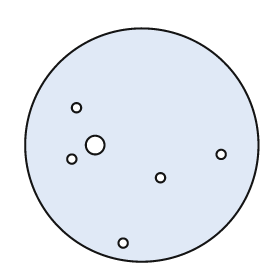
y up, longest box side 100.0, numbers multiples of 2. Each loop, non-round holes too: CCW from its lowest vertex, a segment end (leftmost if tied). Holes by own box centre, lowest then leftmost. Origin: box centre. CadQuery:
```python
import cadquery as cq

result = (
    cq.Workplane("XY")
    .moveTo(0.0, 0.0)
    .circle(50.0)
    .moveTo(-8.0, -42.0)
    .circle(2.0)
    .moveTo(8.0, -14.0)
    .circle(2.0)
    .moveTo(-30.0, -6.0)
    .circle(2.0)
    .moveTo(34.0, -4.0)
    .circle(2.0)
    .moveTo(-20.0, 0.0)
    .circle(4.0)
    .moveTo(-28.0, 16.0)
    .circle(2.0)
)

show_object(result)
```